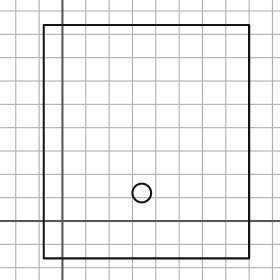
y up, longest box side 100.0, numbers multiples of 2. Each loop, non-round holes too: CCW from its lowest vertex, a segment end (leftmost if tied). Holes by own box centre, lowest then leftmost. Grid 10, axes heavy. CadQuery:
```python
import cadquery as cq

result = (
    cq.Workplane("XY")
    .moveTo(-8.0, -16.0)
    .lineTo(80.0, -16.0)
    .lineTo(80.0, 84.0)
    .lineTo(-8.0, 84.0)
    .close()
    .moveTo(34.0, 12.0)
    .circle(4.0)
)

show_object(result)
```